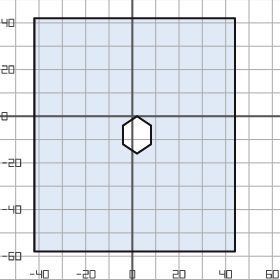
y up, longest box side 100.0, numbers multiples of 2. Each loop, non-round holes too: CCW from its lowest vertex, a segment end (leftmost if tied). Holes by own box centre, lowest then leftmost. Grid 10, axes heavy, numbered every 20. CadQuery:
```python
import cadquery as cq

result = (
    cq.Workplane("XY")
    .moveTo(-42.0, -58.0)
    .lineTo(44.0, -58.0)
    .lineTo(44.0, 42.0)
    .lineTo(-42.0, 42.0)
    .close()
    .moveTo(2.0, -16.0)
    .lineTo(8.0, -12.0)
    .lineTo(8.0, -4.0)
    .lineTo(2.0, 0.0)
    .lineTo(-4.0, -4.0)
    .lineTo(-4.0, -12.0)
    .close()
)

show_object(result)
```